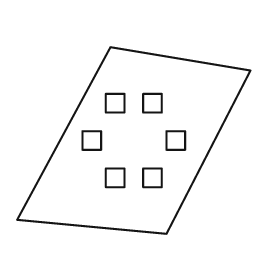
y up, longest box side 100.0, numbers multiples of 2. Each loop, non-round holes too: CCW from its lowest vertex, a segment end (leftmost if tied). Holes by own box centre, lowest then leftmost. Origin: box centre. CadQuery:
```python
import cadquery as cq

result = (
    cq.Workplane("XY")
    .moveTo(14.0, -40.0)
    .lineTo(50.0, 30.0)
    .lineTo(-10.0, 40.0)
    .lineTo(-50.0, -34.0)
    .close()
    .moveTo(-12.0, -20.0)
    .lineTo(-4.0, -20.0)
    .lineTo(-4.0, -12.0)
    .lineTo(-12.0, -12.0)
    .close()
    .moveTo(4.0, -20.0)
    .lineTo(12.0, -20.0)
    .lineTo(12.0, -12.0)
    .lineTo(4.0, -12.0)
    .close()
    .moveTo(-22.0, -4.0)
    .lineTo(-14.0, -4.0)
    .lineTo(-14.0, 4.0)
    .lineTo(-22.0, 4.0)
    .close()
    .moveTo(14.0, -4.0)
    .lineTo(22.0, -4.0)
    .lineTo(22.0, 4.0)
    .lineTo(14.0, 4.0)
    .close()
    .moveTo(-12.0, 12.0)
    .lineTo(-4.0, 12.0)
    .lineTo(-4.0, 20.0)
    .lineTo(-12.0, 20.0)
    .close()
    .moveTo(4.0, 12.0)
    .lineTo(12.0, 12.0)
    .lineTo(12.0, 20.0)
    .lineTo(4.0, 20.0)
    .close()
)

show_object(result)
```